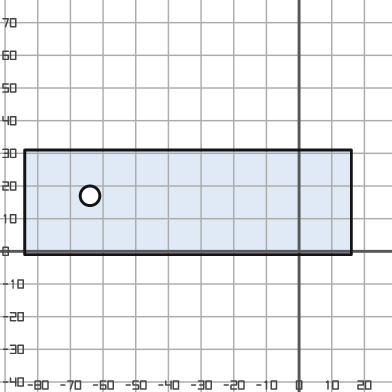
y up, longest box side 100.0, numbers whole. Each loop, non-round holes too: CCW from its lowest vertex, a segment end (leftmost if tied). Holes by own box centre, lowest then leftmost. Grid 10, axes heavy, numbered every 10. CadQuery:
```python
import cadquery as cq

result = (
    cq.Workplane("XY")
    .moveTo(-84.0, -1.0)
    .lineTo(16.0, -1.0)
    .lineTo(16.0, 31.0)
    .lineTo(-84.0, 31.0)
    .close()
    .moveTo(-64.0, 17.0)
    .circle(3.0)
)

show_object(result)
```